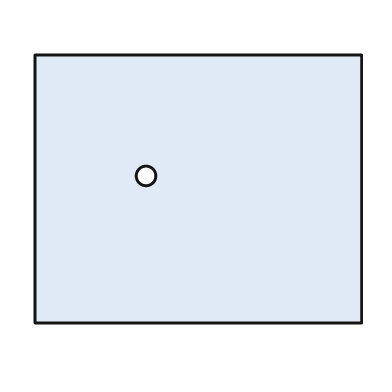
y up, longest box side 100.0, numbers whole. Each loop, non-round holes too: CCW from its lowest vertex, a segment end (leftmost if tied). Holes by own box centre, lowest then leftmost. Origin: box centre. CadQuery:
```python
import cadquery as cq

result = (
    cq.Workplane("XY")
    .moveTo(-50.0, -41.0)
    .lineTo(50.0, -41.0)
    .lineTo(50.0, 41.0)
    .lineTo(-50.0, 41.0)
    .close()
    .moveTo(-16.0, 4.0)
    .circle(3.0)
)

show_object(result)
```